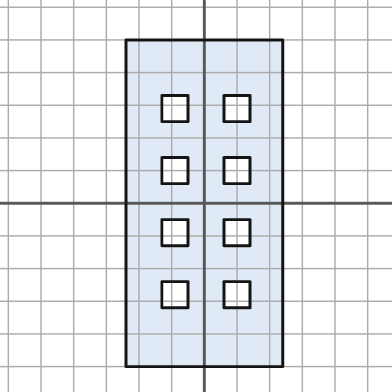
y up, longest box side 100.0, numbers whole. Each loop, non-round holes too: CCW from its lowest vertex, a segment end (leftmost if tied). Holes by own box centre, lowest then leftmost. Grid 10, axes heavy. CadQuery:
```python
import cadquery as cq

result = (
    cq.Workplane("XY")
    .moveTo(-24.0, -50.0)
    .lineTo(24.0, -50.0)
    .lineTo(24.0, 50.0)
    .lineTo(-24.0, 50.0)
    .close()
    .moveTo(-13.0, -32.0)
    .lineTo(-5.0, -32.0)
    .lineTo(-5.0, -24.0)
    .lineTo(-13.0, -24.0)
    .close()
    .moveTo(6.0, -32.0)
    .lineTo(14.0, -32.0)
    .lineTo(14.0, -24.0)
    .lineTo(6.0, -24.0)
    .close()
    .moveTo(-13.0, -13.0)
    .lineTo(-5.0, -13.0)
    .lineTo(-5.0, -5.0)
    .lineTo(-13.0, -5.0)
    .close()
    .moveTo(6.0, -13.0)
    .lineTo(14.0, -13.0)
    .lineTo(14.0, -5.0)
    .lineTo(6.0, -5.0)
    .close()
    .moveTo(-13.0, 6.0)
    .lineTo(-5.0, 6.0)
    .lineTo(-5.0, 14.0)
    .lineTo(-13.0, 14.0)
    .close()
    .moveTo(6.0, 6.0)
    .lineTo(14.0, 6.0)
    .lineTo(14.0, 14.0)
    .lineTo(6.0, 14.0)
    .close()
    .moveTo(-13.0, 25.0)
    .lineTo(-5.0, 25.0)
    .lineTo(-5.0, 33.0)
    .lineTo(-13.0, 33.0)
    .close()
    .moveTo(6.0, 25.0)
    .lineTo(14.0, 25.0)
    .lineTo(14.0, 33.0)
    .lineTo(6.0, 33.0)
    .close()
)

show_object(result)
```